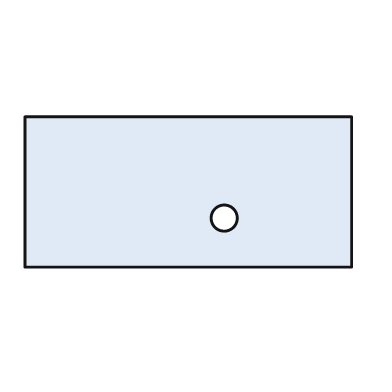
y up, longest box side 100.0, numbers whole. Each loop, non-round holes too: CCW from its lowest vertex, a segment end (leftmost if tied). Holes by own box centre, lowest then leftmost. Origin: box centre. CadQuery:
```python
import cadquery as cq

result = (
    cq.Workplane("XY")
    .moveTo(-50.0, -23.0)
    .lineTo(50.0, -23.0)
    .lineTo(50.0, 23.0)
    .lineTo(-50.0, 23.0)
    .close()
    .moveTo(11.0, -8.0)
    .circle(4.0)
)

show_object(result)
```